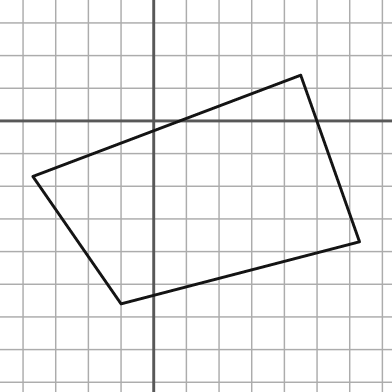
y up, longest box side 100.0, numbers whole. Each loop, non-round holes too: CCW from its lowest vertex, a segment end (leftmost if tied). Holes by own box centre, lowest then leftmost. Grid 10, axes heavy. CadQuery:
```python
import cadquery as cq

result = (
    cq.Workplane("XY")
    .moveTo(-10.0, -56.0)
    .lineTo(63.0, -37.0)
    .lineTo(45.0, 14.0)
    .lineTo(-37.0, -17.0)
    .close()
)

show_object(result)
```